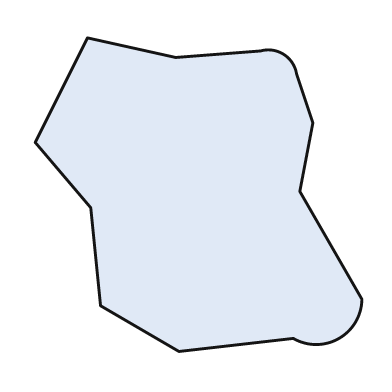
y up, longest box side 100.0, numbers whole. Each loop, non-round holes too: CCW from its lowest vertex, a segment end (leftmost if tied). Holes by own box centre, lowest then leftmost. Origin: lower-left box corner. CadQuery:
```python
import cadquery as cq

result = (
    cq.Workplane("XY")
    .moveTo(44.0, 0.0)
    .lineTo(79.0, 4.0)
    .threePointArc((93.0, 4.0), (100.0, 16.0))
    .lineTo(81.0, 49.0)
    .lineTo(85.0, 70.0)
    .lineTo(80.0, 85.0)
    .threePointArc((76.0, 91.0), (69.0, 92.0))
    .lineTo(43.0, 90.0)
    .lineTo(16.0, 96.0)
    .lineTo(0.0, 64.0)
    .lineTo(17.0, 44.0)
    .lineTo(20.0, 14.0)
    .close()
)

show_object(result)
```